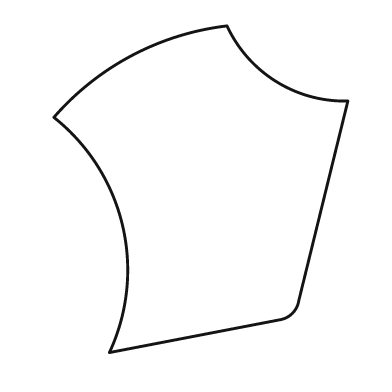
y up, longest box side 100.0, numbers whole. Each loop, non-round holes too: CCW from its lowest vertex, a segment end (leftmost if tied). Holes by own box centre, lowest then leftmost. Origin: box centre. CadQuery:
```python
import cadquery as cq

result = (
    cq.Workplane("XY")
    .moveTo(-28.0, -50.0)
    .lineTo(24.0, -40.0)
    .threePointArc((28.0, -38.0), (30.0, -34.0))
    .lineTo(45.0, 27.0)
    .threePointArc((23.0, 33.0), (8.0, 50.0))
    .threePointArc((-21.0, 41.0), (-45.0, 22.0))
    .threePointArc((-24.0, -11.0), (-28.0, -50.0))
    .close()
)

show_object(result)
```